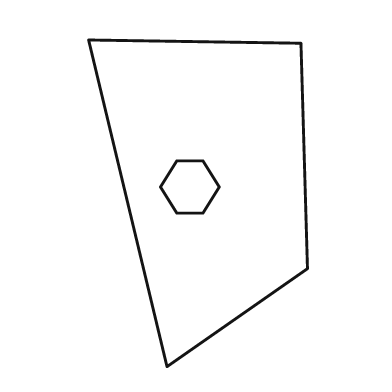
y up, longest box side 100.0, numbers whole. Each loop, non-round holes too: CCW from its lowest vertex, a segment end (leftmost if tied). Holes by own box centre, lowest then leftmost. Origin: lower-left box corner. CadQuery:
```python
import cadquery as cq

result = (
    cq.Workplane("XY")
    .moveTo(24.0, 0.0)
    .lineTo(67.0, 30.0)
    .lineTo(65.0, 99.0)
    .lineTo(0.0, 100.0)
    .close()
    .moveTo(27.0, 47.0)
    .lineTo(35.0, 47.0)
    .lineTo(40.0, 55.0)
    .lineTo(35.0, 63.0)
    .lineTo(27.0, 63.0)
    .lineTo(22.0, 55.0)
    .close()
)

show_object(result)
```